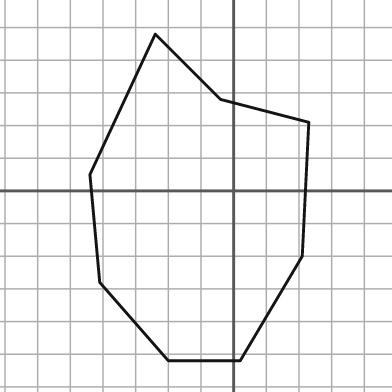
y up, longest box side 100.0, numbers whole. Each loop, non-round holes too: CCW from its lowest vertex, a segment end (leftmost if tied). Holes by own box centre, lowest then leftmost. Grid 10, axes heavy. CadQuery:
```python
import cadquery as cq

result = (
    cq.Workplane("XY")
    .moveTo(-20.0, -52.0)
    .lineTo(2.0, -52.0)
    .lineTo(21.0, -20.0)
    .lineTo(23.0, 21.0)
    .lineTo(-4.0, 28.0)
    .lineTo(-24.0, 48.0)
    .lineTo(-44.0, 5.0)
    .lineTo(-41.0, -28.0)
    .close()
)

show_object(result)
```